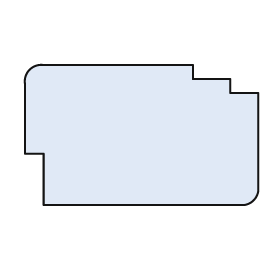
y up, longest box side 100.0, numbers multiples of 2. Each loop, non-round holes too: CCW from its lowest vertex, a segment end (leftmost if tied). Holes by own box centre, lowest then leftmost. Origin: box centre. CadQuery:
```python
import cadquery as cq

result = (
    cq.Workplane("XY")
    .moveTo(-42.0, -30.0)
    .lineTo(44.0, -30.0)
    .threePointArc((48.0, -28.0), (50.0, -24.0))
    .lineTo(50.0, 18.0)
    .lineTo(38.0, 18.0)
    .lineTo(38.0, 24.0)
    .lineTo(22.0, 24.0)
    .lineTo(22.0, 30.0)
    .lineTo(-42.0, 30.0)
    .threePointArc((-48.0, 28.0), (-50.0, 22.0))
    .lineTo(-50.0, -8.0)
    .lineTo(-42.0, -8.0)
    .close()
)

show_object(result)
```